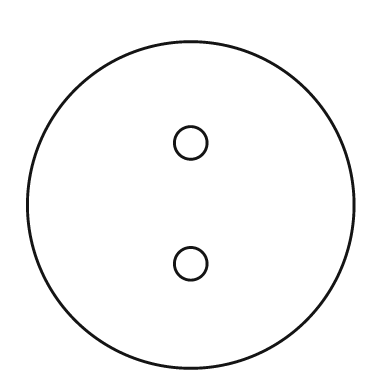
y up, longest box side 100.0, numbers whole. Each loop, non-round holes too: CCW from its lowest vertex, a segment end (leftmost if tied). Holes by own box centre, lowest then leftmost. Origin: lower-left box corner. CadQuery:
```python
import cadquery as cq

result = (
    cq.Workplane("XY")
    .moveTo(50.0, 50.0)
    .circle(50.0)
    .moveTo(50.0, 32.0)
    .circle(5.0)
    .moveTo(50.0, 69.0)
    .circle(5.0)
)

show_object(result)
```